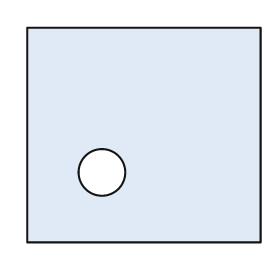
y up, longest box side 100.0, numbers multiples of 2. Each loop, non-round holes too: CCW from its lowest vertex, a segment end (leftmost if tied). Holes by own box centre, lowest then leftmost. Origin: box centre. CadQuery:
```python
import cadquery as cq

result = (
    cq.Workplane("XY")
    .moveTo(-50.0, -46.0)
    .lineTo(50.0, -46.0)
    .lineTo(50.0, 46.0)
    .lineTo(-50.0, 46.0)
    .close()
    .moveTo(-18.0, -16.0)
    .circle(10.0)
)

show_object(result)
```